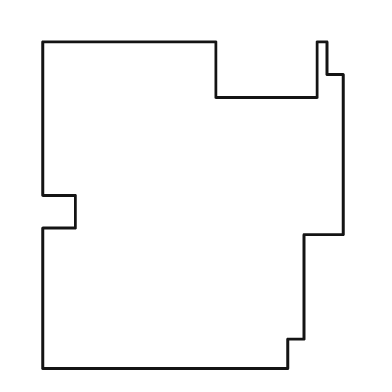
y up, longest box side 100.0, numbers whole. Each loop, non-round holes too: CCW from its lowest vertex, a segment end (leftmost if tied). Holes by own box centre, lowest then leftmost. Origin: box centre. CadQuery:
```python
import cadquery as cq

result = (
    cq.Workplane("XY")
    .moveTo(-46.0, -50.0)
    .lineTo(29.0, -50.0)
    .lineTo(29.0, -41.0)
    .lineTo(34.0, -41.0)
    .lineTo(34.0, -9.0)
    .lineTo(46.0, -9.0)
    .lineTo(46.0, 40.0)
    .lineTo(41.0, 40.0)
    .lineTo(41.0, 50.0)
    .lineTo(38.0, 50.0)
    .lineTo(38.0, 33.0)
    .lineTo(7.0, 33.0)
    .lineTo(7.0, 50.0)
    .lineTo(-46.0, 50.0)
    .lineTo(-46.0, 3.0)
    .lineTo(-36.0, 3.0)
    .lineTo(-36.0, -7.0)
    .lineTo(-46.0, -7.0)
    .close()
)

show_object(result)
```